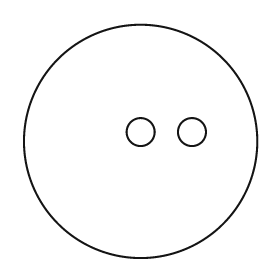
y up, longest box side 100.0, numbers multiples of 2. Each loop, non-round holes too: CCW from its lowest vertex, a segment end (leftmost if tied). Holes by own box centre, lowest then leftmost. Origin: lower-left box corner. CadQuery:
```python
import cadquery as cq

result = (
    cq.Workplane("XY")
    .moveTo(50.0, 50.0)
    .circle(50.0)
    .moveTo(50.0, 54.0)
    .circle(6.0)
    .moveTo(72.0, 54.0)
    .circle(6.0)
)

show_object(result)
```